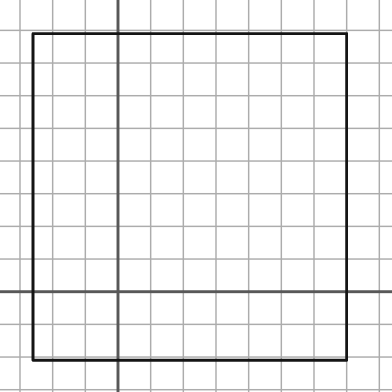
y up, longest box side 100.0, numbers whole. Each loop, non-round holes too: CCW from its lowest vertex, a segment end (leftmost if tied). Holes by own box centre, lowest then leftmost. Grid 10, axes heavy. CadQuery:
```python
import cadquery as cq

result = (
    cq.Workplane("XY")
    .moveTo(-26.0, -21.0)
    .lineTo(70.0, -21.0)
    .lineTo(70.0, 79.0)
    .lineTo(-26.0, 79.0)
    .close()
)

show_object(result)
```